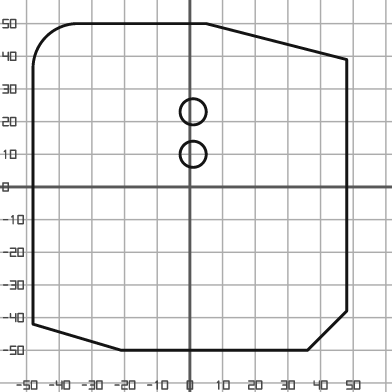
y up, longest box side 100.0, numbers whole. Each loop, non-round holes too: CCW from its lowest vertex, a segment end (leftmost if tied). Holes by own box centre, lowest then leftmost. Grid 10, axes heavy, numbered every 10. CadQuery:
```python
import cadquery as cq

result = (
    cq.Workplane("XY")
    .moveTo(-21.0, -50.0)
    .lineTo(36.0, -50.0)
    .lineTo(48.0, -38.0)
    .lineTo(48.0, 39.0)
    .lineTo(5.0, 50.0)
    .lineTo(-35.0, 50.0)
    .threePointArc((-44.0, 46.0), (-48.0, 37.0))
    .lineTo(-48.0, -42.0)
    .close()
    .moveTo(1.0, 10.0)
    .circle(4.0)
    .moveTo(1.0, 23.0)
    .circle(4.0)
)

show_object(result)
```